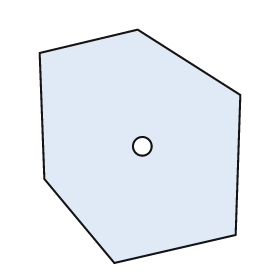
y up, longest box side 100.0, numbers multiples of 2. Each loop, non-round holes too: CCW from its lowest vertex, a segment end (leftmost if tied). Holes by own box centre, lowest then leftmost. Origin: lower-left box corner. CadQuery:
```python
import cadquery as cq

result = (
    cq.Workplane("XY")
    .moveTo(32.0, 0.0)
    .lineTo(84.0, 12.0)
    .lineTo(86.0, 72.0)
    .lineTo(42.0, 100.0)
    .lineTo(0.0, 90.0)
    .lineTo(2.0, 36.0)
    .close()
    .moveTo(44.0, 50.0)
    .circle(4.0)
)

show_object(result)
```